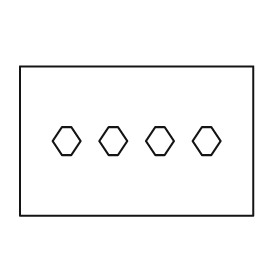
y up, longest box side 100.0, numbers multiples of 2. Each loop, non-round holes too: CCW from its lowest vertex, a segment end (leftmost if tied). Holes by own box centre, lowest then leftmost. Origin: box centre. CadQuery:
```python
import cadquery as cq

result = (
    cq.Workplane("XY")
    .moveTo(-50.0, -32.0)
    .lineTo(50.0, -32.0)
    .lineTo(50.0, 32.0)
    .lineTo(-50.0, 32.0)
    .close()
    .moveTo(-32.0, -6.0)
    .lineTo(-28.0, -6.0)
    .lineTo(-24.0, 0.0)
    .lineTo(-28.0, 6.0)
    .lineTo(-32.0, 6.0)
    .lineTo(-36.0, 0.0)
    .close()
    .moveTo(-12.0, -6.0)
    .lineTo(-8.0, -6.0)
    .lineTo(-4.0, 0.0)
    .lineTo(-8.0, 6.0)
    .lineTo(-12.0, 6.0)
    .lineTo(-16.0, 0.0)
    .close()
    .moveTo(8.0, -6.0)
    .lineTo(12.0, -6.0)
    .lineTo(16.0, 0.0)
    .lineTo(12.0, 6.0)
    .lineTo(8.0, 6.0)
    .lineTo(4.0, 0.0)
    .close()
    .moveTo(28.0, -6.0)
    .lineTo(32.0, -6.0)
    .lineTo(36.0, 0.0)
    .lineTo(32.0, 6.0)
    .lineTo(28.0, 6.0)
    .lineTo(24.0, 0.0)
    .close()
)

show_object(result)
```